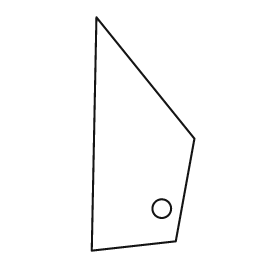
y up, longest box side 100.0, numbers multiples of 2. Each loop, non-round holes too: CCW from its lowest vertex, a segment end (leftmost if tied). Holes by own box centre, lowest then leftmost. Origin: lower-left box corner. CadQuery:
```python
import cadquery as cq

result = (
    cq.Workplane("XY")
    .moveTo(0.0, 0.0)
    .lineTo(36.0, 4.0)
    .lineTo(44.0, 48.0)
    .lineTo(2.0, 100.0)
    .close()
    .moveTo(30.0, 18.0)
    .circle(4.0)
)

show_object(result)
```